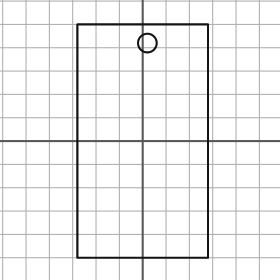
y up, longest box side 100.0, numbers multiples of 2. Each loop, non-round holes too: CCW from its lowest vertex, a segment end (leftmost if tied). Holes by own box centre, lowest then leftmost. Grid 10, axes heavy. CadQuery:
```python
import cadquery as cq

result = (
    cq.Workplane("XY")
    .moveTo(-28.0, -50.0)
    .lineTo(28.0, -50.0)
    .lineTo(28.0, 50.0)
    .lineTo(-28.0, 50.0)
    .close()
    .moveTo(2.0, 42.0)
    .circle(4.0)
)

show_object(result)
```